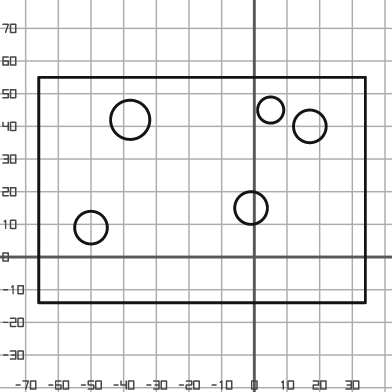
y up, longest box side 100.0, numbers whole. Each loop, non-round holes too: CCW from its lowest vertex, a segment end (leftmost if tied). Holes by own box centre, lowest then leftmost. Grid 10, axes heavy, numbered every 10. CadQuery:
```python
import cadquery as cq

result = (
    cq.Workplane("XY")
    .moveTo(-66.0, -14.0)
    .lineTo(34.0, -14.0)
    .lineTo(34.0, 55.0)
    .lineTo(-66.0, 55.0)
    .close()
    .moveTo(-50.0, 9.0)
    .circle(5.0)
    .moveTo(-1.0, 15.0)
    .circle(5.0)
    .moveTo(17.0, 40.0)
    .circle(5.0)
    .moveTo(-38.0, 42.0)
    .circle(6.0)
    .moveTo(5.0, 45.0)
    .circle(4.0)
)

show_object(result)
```